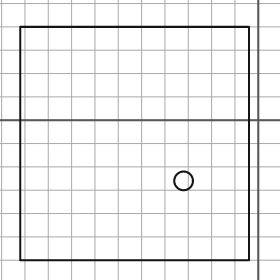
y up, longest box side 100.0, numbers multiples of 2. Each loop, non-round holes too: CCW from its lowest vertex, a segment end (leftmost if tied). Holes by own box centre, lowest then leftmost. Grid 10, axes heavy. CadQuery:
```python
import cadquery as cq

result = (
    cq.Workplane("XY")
    .moveTo(-102.0, -60.0)
    .lineTo(-4.0, -60.0)
    .lineTo(-4.0, 40.0)
    .lineTo(-102.0, 40.0)
    .close()
    .moveTo(-32.0, -26.0)
    .circle(4.0)
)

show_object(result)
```